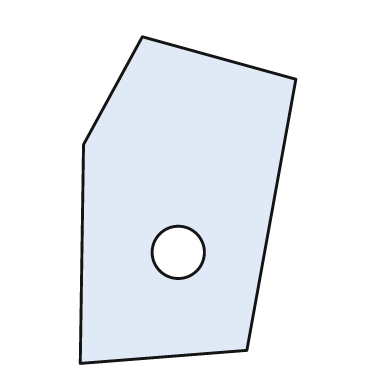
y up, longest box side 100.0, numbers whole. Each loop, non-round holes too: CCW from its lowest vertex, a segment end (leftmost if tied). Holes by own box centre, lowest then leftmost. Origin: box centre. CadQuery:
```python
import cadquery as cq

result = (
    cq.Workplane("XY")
    .moveTo(-33.0, -50.0)
    .lineTo(18.0, -46.0)
    .lineTo(33.0, 37.0)
    .lineTo(-14.0, 50.0)
    .lineTo(-32.0, 17.0)
    .close()
    .moveTo(-3.0, -16.0)
    .circle(8.0)
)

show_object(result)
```